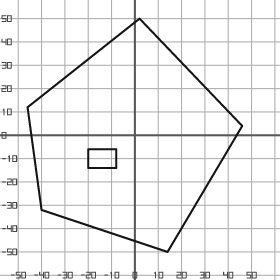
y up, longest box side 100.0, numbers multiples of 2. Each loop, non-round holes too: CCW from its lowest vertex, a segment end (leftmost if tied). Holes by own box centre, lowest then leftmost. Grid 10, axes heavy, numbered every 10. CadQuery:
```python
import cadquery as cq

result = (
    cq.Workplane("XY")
    .moveTo(14.0, -50.0)
    .lineTo(46.0, 4.0)
    .lineTo(2.0, 50.0)
    .lineTo(-46.0, 12.0)
    .lineTo(-40.0, -32.0)
    .close()
    .moveTo(-20.0, -14.0)
    .lineTo(-8.0, -14.0)
    .lineTo(-8.0, -6.0)
    .lineTo(-20.0, -6.0)
    .close()
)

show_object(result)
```